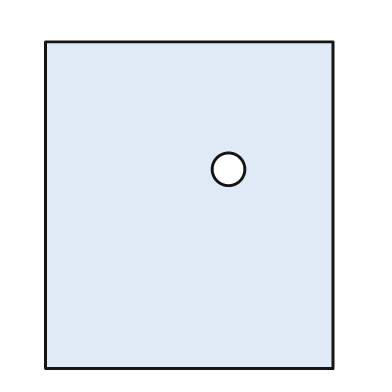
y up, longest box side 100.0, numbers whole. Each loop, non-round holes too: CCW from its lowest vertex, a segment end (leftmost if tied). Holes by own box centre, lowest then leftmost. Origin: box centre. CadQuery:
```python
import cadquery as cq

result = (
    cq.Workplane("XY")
    .moveTo(-44.0, -50.0)
    .lineTo(44.0, -50.0)
    .lineTo(44.0, 50.0)
    .lineTo(-44.0, 50.0)
    .close()
    .moveTo(12.0, 11.0)
    .circle(5.0)
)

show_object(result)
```